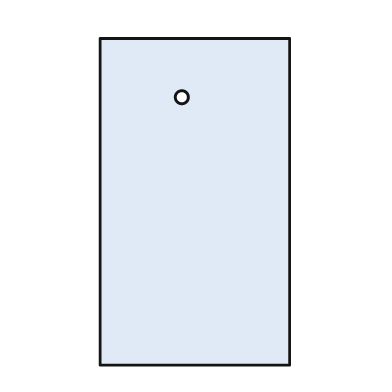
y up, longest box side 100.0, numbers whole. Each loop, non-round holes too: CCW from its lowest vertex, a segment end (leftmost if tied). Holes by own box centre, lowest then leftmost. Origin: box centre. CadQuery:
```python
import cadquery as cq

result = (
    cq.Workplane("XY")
    .moveTo(-29.0, -50.0)
    .lineTo(29.0, -50.0)
    .lineTo(29.0, 50.0)
    .lineTo(-29.0, 50.0)
    .close()
    .moveTo(-4.0, 32.0)
    .circle(2.0)
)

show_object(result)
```